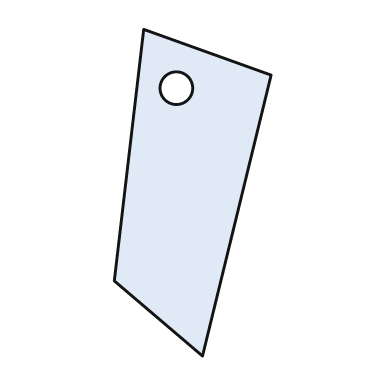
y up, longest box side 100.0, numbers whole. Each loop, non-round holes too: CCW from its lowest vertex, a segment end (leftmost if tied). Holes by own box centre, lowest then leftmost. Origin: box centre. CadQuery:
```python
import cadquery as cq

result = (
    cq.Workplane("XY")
    .moveTo(3.0, -50.0)
    .lineTo(24.0, 36.0)
    .lineTo(-15.0, 50.0)
    .lineTo(-24.0, -27.0)
    .close()
    .moveTo(-5.0, 32.0)
    .circle(5.0)
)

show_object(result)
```